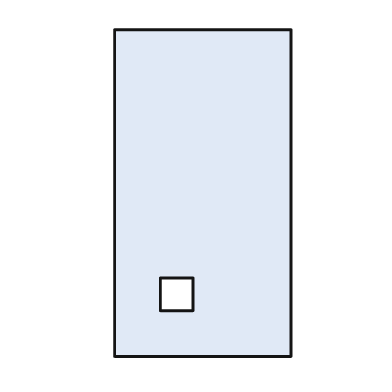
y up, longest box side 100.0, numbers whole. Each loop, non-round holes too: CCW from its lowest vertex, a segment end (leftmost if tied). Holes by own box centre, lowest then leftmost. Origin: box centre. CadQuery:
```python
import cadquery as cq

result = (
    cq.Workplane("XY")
    .moveTo(-27.0, -50.0)
    .lineTo(27.0, -50.0)
    .lineTo(27.0, 50.0)
    .lineTo(-27.0, 50.0)
    .close()
    .moveTo(-13.0, -36.0)
    .lineTo(-3.0, -36.0)
    .lineTo(-3.0, -26.0)
    .lineTo(-13.0, -26.0)
    .close()
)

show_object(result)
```